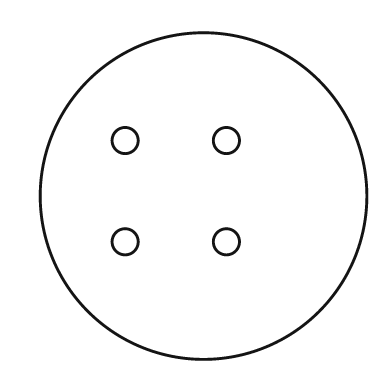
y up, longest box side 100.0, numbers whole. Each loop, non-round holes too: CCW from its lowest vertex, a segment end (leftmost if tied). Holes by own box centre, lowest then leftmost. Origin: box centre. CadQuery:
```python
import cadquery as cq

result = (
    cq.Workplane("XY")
    .moveTo(0.0, 0.0)
    .circle(50.0)
    .moveTo(-24.0, -14.0)
    .circle(4.0)
    .moveTo(7.0, -14.0)
    .circle(4.0)
    .moveTo(-24.0, 17.0)
    .circle(4.0)
    .moveTo(7.0, 17.0)
    .circle(4.0)
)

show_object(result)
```